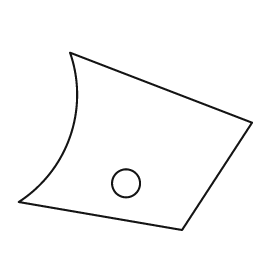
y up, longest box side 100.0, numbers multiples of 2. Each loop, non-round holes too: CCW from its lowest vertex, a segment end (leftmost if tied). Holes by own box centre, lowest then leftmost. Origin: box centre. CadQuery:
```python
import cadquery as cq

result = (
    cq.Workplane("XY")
    .moveTo(20.0, -38.0)
    .lineTo(50.0, 8.0)
    .lineTo(-28.0, 38.0)
    .threePointArc((-28.0, 2.0), (-50.0, -26.0))
    .close()
    .moveTo(-4.0, -18.0)
    .circle(6.0)
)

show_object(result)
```